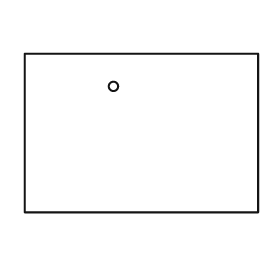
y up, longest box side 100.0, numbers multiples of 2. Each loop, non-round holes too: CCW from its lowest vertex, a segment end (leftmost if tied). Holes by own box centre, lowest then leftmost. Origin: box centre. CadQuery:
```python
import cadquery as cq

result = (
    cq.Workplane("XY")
    .moveTo(-50.0, -34.0)
    .lineTo(50.0, -34.0)
    .lineTo(50.0, 34.0)
    .lineTo(-50.0, 34.0)
    .close()
    .moveTo(-12.0, 20.0)
    .circle(2.0)
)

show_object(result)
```